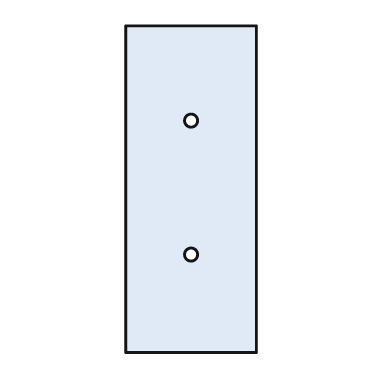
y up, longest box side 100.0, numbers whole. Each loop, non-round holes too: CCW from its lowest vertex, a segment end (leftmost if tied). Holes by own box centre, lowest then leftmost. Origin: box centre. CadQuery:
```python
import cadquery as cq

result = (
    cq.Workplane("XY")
    .moveTo(-20.0, -50.0)
    .lineTo(20.0, -50.0)
    .lineTo(20.0, 50.0)
    .lineTo(-20.0, 50.0)
    .close()
    .moveTo(0.0, -20.0)
    .circle(2.0)
    .moveTo(0.0, 21.0)
    .circle(2.0)
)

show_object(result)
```